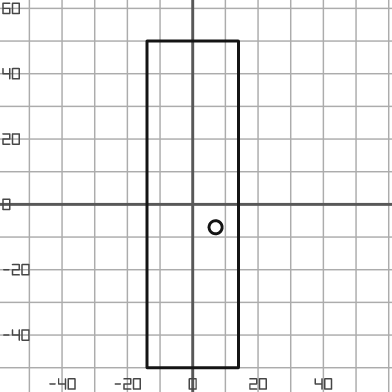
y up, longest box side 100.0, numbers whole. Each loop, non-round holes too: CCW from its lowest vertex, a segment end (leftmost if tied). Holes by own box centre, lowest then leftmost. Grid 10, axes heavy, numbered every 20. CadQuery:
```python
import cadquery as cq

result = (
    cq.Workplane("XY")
    .moveTo(-14.0, -50.0)
    .lineTo(14.0, -50.0)
    .lineTo(14.0, 50.0)
    .lineTo(-14.0, 50.0)
    .close()
    .moveTo(7.0, -7.0)
    .circle(2.0)
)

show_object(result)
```